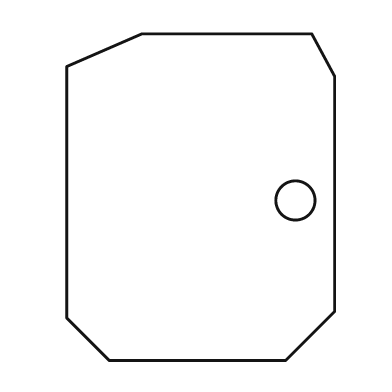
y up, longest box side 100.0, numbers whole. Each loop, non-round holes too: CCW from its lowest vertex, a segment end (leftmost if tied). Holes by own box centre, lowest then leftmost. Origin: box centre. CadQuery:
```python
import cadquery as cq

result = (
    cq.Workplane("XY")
    .moveTo(-28.0, -50.0)
    .lineTo(26.0, -50.0)
    .lineTo(41.0, -35.0)
    .lineTo(41.0, 37.0)
    .lineTo(34.0, 50.0)
    .lineTo(-18.0, 50.0)
    .lineTo(-41.0, 40.0)
    .lineTo(-41.0, -37.0)
    .close()
    .moveTo(29.0, -1.0)
    .circle(6.0)
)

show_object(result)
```